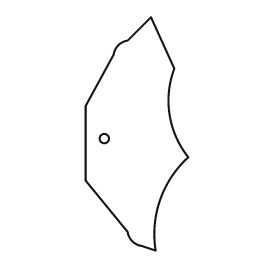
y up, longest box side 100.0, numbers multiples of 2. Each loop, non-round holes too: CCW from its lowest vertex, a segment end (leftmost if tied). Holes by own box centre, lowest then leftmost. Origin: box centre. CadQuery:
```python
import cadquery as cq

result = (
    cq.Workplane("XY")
    .moveTo(8.0, -50.0)
    .threePointArc((10.0, -28.0), (22.0, -10.0))
    .threePointArc((14.0, 8.0), (16.0, 28.0))
    .lineTo(6.0, 50.0)
    .lineTo(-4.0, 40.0)
    .threePointArc((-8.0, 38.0), (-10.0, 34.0))
    .lineTo(-22.0, 12.0)
    .lineTo(-22.0, -20.0)
    .lineTo(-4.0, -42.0)
    .threePointArc((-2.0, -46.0), (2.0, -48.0))
    .close()
    .moveTo(-14.0, -2.0)
    .circle(2.0)
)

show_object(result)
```